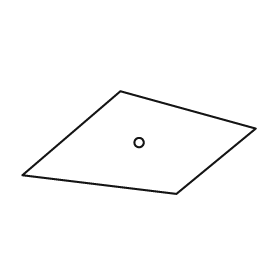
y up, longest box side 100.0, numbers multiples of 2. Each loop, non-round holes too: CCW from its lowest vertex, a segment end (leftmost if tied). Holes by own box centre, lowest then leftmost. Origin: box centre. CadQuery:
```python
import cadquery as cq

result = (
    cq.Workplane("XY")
    .moveTo(16.0, -22.0)
    .lineTo(50.0, 6.0)
    .lineTo(-8.0, 22.0)
    .lineTo(-50.0, -14.0)
    .close()
    .moveTo(0.0, 0.0)
    .circle(2.0)
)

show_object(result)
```